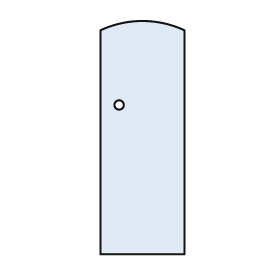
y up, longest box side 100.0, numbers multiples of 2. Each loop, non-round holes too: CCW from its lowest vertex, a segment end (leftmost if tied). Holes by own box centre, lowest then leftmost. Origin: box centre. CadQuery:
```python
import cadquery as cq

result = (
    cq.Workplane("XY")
    .moveTo(-18.0, -50.0)
    .lineTo(18.0, -50.0)
    .lineTo(18.0, 46.0)
    .threePointArc((0.0, 50.0), (-18.0, 46.0))
    .close()
    .moveTo(-10.0, 14.0)
    .circle(2.0)
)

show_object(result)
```